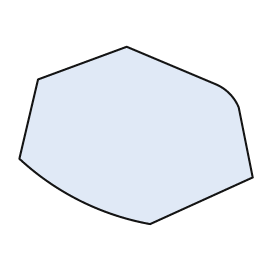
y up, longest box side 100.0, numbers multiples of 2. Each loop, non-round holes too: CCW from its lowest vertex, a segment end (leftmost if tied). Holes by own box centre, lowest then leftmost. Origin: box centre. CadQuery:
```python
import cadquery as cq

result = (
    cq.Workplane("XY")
    .moveTo(6.0, -38.0)
    .lineTo(50.0, -18.0)
    .lineTo(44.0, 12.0)
    .threePointArc((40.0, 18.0), (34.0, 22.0))
    .lineTo(-4.0, 38.0)
    .lineTo(-42.0, 24.0)
    .lineTo(-50.0, -10.0)
    .threePointArc((-24.0, -28.0), (6.0, -38.0))
    .close()
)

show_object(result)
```